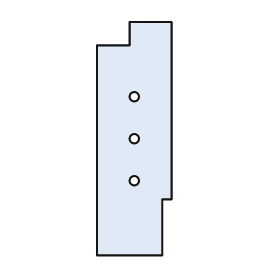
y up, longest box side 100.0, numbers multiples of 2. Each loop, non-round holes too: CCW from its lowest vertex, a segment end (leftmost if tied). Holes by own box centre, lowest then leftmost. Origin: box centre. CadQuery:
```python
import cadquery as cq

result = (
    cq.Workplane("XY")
    .moveTo(-16.0, -50.0)
    .lineTo(12.0, -50.0)
    .lineTo(12.0, -26.0)
    .lineTo(16.0, -26.0)
    .lineTo(16.0, 50.0)
    .lineTo(-2.0, 50.0)
    .lineTo(-2.0, 40.0)
    .lineTo(-16.0, 40.0)
    .close()
    .moveTo(0.0, -18.0)
    .circle(2.0)
    .moveTo(0.0, 0.0)
    .circle(2.0)
    .moveTo(0.0, 18.0)
    .circle(2.0)
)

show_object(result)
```